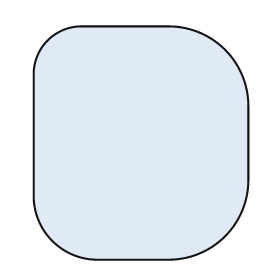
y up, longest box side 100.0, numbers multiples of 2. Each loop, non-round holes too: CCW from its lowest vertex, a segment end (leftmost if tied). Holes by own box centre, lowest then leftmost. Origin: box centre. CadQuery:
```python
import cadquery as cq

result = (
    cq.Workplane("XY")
    .moveTo(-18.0, -50.0)
    .lineTo(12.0, -50.0)
    .threePointArc((36.0, -40.0), (46.0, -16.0))
    .lineTo(46.0, 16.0)
    .threePointArc((36.0, 40.0), (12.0, 50.0))
    .lineTo(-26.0, 50.0)
    .threePointArc((-40.0, 44.0), (-46.0, 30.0))
    .lineTo(-46.0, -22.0)
    .threePointArc((-38.0, -42.0), (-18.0, -50.0))
    .close()
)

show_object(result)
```